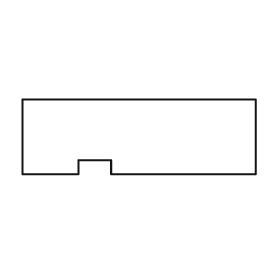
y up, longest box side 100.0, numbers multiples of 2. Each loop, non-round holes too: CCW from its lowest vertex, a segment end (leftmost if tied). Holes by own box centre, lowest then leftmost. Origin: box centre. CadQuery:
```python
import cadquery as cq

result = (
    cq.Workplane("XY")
    .moveTo(-50.0, -16.0)
    .lineTo(-26.0, -16.0)
    .lineTo(-26.0, -10.0)
    .lineTo(-12.0, -10.0)
    .lineTo(-12.0, -16.0)
    .lineTo(50.0, -16.0)
    .lineTo(50.0, 16.0)
    .lineTo(-50.0, 16.0)
    .close()
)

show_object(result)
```